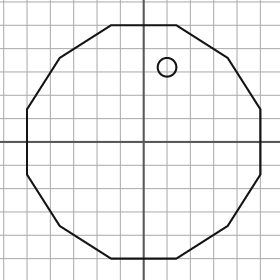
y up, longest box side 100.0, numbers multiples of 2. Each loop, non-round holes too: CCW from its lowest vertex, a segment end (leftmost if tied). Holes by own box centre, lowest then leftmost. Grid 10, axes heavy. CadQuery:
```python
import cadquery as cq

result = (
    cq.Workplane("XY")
    .moveTo(-14.0, -50.0)
    .lineTo(14.0, -50.0)
    .lineTo(36.0, -36.0)
    .lineTo(50.0, -14.0)
    .lineTo(50.0, 14.0)
    .lineTo(36.0, 36.0)
    .lineTo(14.0, 50.0)
    .lineTo(-14.0, 50.0)
    .lineTo(-36.0, 36.0)
    .lineTo(-50.0, 14.0)
    .lineTo(-50.0, -14.0)
    .lineTo(-36.0, -36.0)
    .close()
    .moveTo(10.0, 32.0)
    .circle(4.0)
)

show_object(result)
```